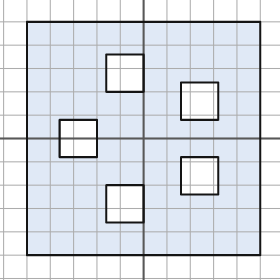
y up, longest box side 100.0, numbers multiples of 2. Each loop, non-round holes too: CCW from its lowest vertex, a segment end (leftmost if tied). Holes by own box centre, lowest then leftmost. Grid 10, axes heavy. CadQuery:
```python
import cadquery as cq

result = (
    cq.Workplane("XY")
    .moveTo(-50.0, -50.0)
    .lineTo(50.0, -50.0)
    .lineTo(50.0, 50.0)
    .lineTo(-50.0, 50.0)
    .close()
    .moveTo(-16.0, -36.0)
    .lineTo(0.0, -36.0)
    .lineTo(0.0, -20.0)
    .lineTo(-16.0, -20.0)
    .close()
    .moveTo(16.0, -24.0)
    .lineTo(32.0, -24.0)
    .lineTo(32.0, -8.0)
    .lineTo(16.0, -8.0)
    .close()
    .moveTo(-36.0, -8.0)
    .lineTo(-20.0, -8.0)
    .lineTo(-20.0, 8.0)
    .lineTo(-36.0, 8.0)
    .close()
    .moveTo(16.0, 8.0)
    .lineTo(32.0, 8.0)
    .lineTo(32.0, 24.0)
    .lineTo(16.0, 24.0)
    .close()
    .moveTo(-16.0, 20.0)
    .lineTo(0.0, 20.0)
    .lineTo(0.0, 36.0)
    .lineTo(-16.0, 36.0)
    .close()
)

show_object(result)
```